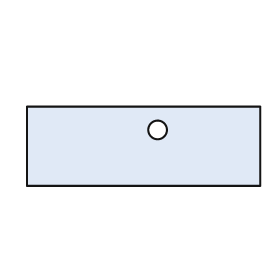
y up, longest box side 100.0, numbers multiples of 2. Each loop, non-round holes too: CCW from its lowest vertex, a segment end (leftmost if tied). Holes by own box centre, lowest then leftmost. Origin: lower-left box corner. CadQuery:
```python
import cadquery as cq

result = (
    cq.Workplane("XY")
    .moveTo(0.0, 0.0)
    .lineTo(100.0, 0.0)
    .lineTo(100.0, 34.0)
    .lineTo(0.0, 34.0)
    .close()
    .moveTo(56.0, 24.0)
    .circle(4.0)
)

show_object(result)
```